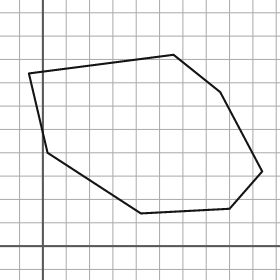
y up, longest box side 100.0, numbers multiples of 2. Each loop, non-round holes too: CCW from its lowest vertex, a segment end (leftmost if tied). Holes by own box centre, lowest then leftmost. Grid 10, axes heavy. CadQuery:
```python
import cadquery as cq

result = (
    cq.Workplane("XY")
    .moveTo(42.0, 14.0)
    .lineTo(80.0, 16.0)
    .lineTo(94.0, 32.0)
    .lineTo(76.0, 66.0)
    .lineTo(56.0, 82.0)
    .lineTo(-6.0, 74.0)
    .lineTo(2.0, 40.0)
    .close()
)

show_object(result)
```